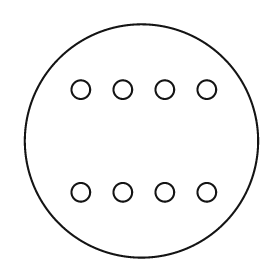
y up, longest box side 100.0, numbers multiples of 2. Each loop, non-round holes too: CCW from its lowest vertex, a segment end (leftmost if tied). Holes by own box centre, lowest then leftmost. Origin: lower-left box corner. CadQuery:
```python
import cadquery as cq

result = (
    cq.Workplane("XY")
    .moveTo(50.0, 50.0)
    .circle(50.0)
    .moveTo(24.0, 28.0)
    .circle(4.0)
    .moveTo(42.0, 28.0)
    .circle(4.0)
    .moveTo(60.0, 28.0)
    .circle(4.0)
    .moveTo(78.0, 28.0)
    .circle(4.0)
    .moveTo(24.0, 72.0)
    .circle(4.0)
    .moveTo(42.0, 72.0)
    .circle(4.0)
    .moveTo(60.0, 72.0)
    .circle(4.0)
    .moveTo(78.0, 72.0)
    .circle(4.0)
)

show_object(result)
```